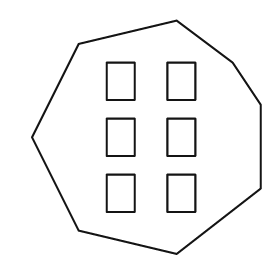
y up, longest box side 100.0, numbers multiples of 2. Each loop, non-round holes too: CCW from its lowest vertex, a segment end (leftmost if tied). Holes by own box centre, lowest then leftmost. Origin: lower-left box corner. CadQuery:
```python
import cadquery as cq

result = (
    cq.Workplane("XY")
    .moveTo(62.0, 0.0)
    .lineTo(98.0, 28.0)
    .lineTo(98.0, 64.0)
    .lineTo(86.0, 82.0)
    .lineTo(62.0, 100.0)
    .lineTo(20.0, 90.0)
    .lineTo(0.0, 50.0)
    .lineTo(20.0, 10.0)
    .close()
    .moveTo(32.0, 18.0)
    .lineTo(44.0, 18.0)
    .lineTo(44.0, 34.0)
    .lineTo(32.0, 34.0)
    .close()
    .moveTo(58.0, 18.0)
    .lineTo(70.0, 18.0)
    .lineTo(70.0, 34.0)
    .lineTo(58.0, 34.0)
    .close()
    .moveTo(32.0, 42.0)
    .lineTo(44.0, 42.0)
    .lineTo(44.0, 58.0)
    .lineTo(32.0, 58.0)
    .close()
    .moveTo(58.0, 42.0)
    .lineTo(70.0, 42.0)
    .lineTo(70.0, 58.0)
    .lineTo(58.0, 58.0)
    .close()
    .moveTo(32.0, 66.0)
    .lineTo(44.0, 66.0)
    .lineTo(44.0, 82.0)
    .lineTo(32.0, 82.0)
    .close()
    .moveTo(58.0, 66.0)
    .lineTo(70.0, 66.0)
    .lineTo(70.0, 82.0)
    .lineTo(58.0, 82.0)
    .close()
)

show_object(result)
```